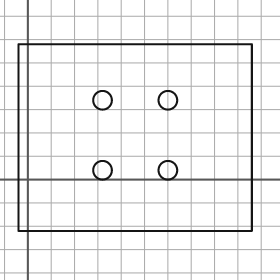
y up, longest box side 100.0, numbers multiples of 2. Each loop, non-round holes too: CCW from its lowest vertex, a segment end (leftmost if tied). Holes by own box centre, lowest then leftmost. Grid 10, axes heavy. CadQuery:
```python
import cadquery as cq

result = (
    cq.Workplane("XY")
    .moveTo(-4.0, -22.0)
    .lineTo(96.0, -22.0)
    .lineTo(96.0, 58.0)
    .lineTo(-4.0, 58.0)
    .close()
    .moveTo(32.0, 4.0)
    .circle(4.0)
    .moveTo(60.0, 4.0)
    .circle(4.0)
    .moveTo(32.0, 34.0)
    .circle(4.0)
    .moveTo(60.0, 34.0)
    .circle(4.0)
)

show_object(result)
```